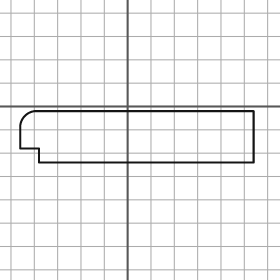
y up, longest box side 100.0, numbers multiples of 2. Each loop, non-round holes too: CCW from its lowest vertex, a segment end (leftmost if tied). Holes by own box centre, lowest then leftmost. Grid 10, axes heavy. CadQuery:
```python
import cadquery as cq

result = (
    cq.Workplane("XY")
    .moveTo(-38.0, -24.0)
    .lineTo(54.0, -24.0)
    .lineTo(54.0, -2.0)
    .lineTo(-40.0, -2.0)
    .threePointArc((-44.0, -4.0), (-46.0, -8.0))
    .lineTo(-46.0, -18.0)
    .lineTo(-38.0, -18.0)
    .close()
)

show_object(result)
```